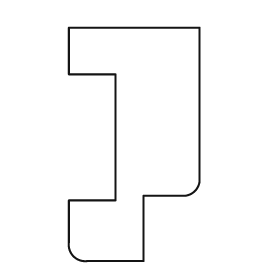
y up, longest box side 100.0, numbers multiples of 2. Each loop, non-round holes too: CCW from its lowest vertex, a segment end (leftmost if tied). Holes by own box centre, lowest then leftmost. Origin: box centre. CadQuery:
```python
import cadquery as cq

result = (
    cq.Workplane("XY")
    .moveTo(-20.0, -50.0)
    .lineTo(4.0, -50.0)
    .lineTo(4.0, -22.0)
    .lineTo(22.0, -22.0)
    .threePointArc((26.0, -20.0), (28.0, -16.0))
    .lineTo(28.0, 50.0)
    .lineTo(-28.0, 50.0)
    .lineTo(-28.0, 30.0)
    .lineTo(-8.0, 30.0)
    .lineTo(-8.0, -24.0)
    .lineTo(-28.0, -24.0)
    .lineTo(-28.0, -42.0)
    .threePointArc((-26.0, -48.0), (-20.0, -50.0))
    .close()
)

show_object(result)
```